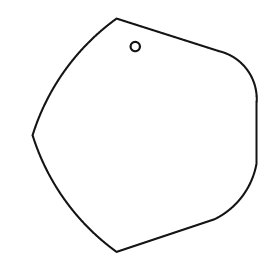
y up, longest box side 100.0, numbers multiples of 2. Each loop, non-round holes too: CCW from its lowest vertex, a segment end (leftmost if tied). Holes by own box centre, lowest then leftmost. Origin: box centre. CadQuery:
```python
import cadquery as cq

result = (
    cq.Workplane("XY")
    .moveTo(-12.0, -50.0)
    .lineTo(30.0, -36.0)
    .threePointArc((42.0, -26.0), (48.0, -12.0))
    .lineTo(48.0, 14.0)
    .threePointArc((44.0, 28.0), (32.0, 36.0))
    .lineTo(-12.0, 50.0)
    .threePointArc((-34.0, 28.0), (-48.0, 0.0))
    .threePointArc((-34.0, -28.0), (-12.0, -50.0))
    .close()
    .moveTo(-4.0, 38.0)
    .circle(2.0)
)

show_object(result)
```